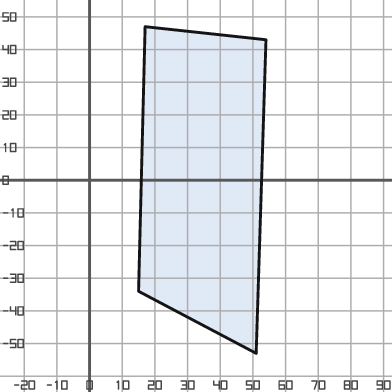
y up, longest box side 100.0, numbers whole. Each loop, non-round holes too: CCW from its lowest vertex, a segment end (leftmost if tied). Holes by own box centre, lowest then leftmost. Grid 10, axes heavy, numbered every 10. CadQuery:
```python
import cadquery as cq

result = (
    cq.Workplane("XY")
    .moveTo(51.0, -53.0)
    .lineTo(54.0, 43.0)
    .lineTo(17.0, 47.0)
    .lineTo(15.0, -34.0)
    .close()
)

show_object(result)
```